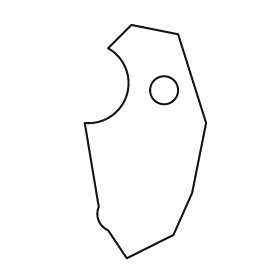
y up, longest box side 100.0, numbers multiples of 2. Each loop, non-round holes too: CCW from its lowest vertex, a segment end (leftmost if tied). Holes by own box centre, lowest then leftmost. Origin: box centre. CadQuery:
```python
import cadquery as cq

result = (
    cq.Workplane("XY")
    .moveTo(-8.0, -50.0)
    .lineTo(12.0, -40.0)
    .lineTo(20.0, -22.0)
    .lineTo(26.0, 8.0)
    .lineTo(14.0, 46.0)
    .lineTo(-6.0, 50.0)
    .lineTo(-16.0, 40.0)
    .threePointArc((-8.0, 20.0), (-26.0, 8.0))
    .lineTo(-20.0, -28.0)
    .threePointArc((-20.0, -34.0), (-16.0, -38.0))
    .close()
    .moveTo(8.0, 22.0)
    .circle(6.0)
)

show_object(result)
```